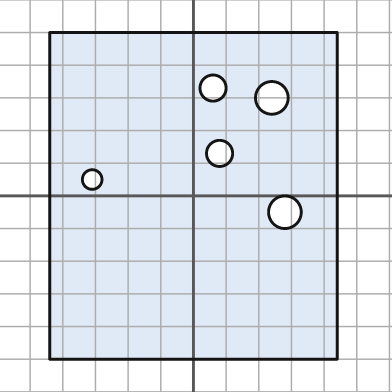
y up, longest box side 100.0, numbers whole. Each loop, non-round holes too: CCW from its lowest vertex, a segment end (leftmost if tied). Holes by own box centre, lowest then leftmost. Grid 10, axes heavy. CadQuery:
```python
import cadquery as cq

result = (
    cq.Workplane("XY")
    .moveTo(-44.0, -50.0)
    .lineTo(44.0, -50.0)
    .lineTo(44.0, 50.0)
    .lineTo(-44.0, 50.0)
    .close()
    .moveTo(28.0, -5.0)
    .circle(5.0)
    .moveTo(-31.0, 5.0)
    .circle(3.0)
    .moveTo(8.0, 13.0)
    .circle(4.0)
    .moveTo(24.0, 30.0)
    .circle(5.0)
    .moveTo(6.0, 33.0)
    .circle(4.0)
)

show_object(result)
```